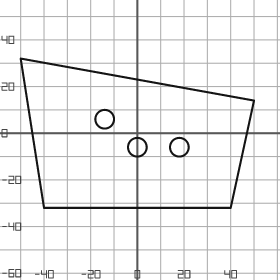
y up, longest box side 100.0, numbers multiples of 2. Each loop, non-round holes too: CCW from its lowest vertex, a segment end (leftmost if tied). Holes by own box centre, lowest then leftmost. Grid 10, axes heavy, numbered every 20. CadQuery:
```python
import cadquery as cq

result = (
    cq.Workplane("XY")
    .moveTo(-40.0, -32.0)
    .lineTo(40.0, -32.0)
    .lineTo(50.0, 14.0)
    .lineTo(-50.0, 32.0)
    .close()
    .moveTo(0.0, -6.0)
    .circle(4.0)
    .moveTo(18.0, -6.0)
    .circle(4.0)
    .moveTo(-14.0, 6.0)
    .circle(4.0)
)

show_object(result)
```